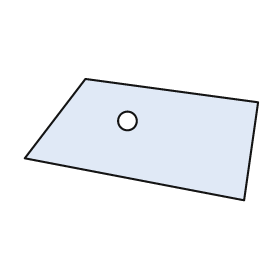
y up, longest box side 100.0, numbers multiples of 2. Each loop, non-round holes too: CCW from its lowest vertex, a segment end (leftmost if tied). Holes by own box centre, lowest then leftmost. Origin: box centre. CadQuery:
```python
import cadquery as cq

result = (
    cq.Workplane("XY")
    .moveTo(44.0, -26.0)
    .lineTo(50.0, 16.0)
    .lineTo(-24.0, 26.0)
    .lineTo(-50.0, -8.0)
    .close()
    .moveTo(-6.0, 8.0)
    .circle(4.0)
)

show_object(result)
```